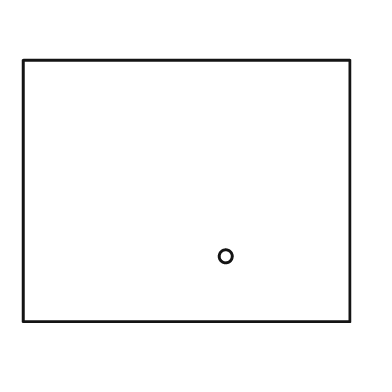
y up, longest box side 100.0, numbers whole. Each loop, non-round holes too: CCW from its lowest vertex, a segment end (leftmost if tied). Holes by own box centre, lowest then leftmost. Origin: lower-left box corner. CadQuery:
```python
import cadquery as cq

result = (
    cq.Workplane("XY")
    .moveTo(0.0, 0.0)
    .lineTo(100.0, 0.0)
    .lineTo(100.0, 80.0)
    .lineTo(0.0, 80.0)
    .close()
    .moveTo(62.0, 20.0)
    .circle(2.0)
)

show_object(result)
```